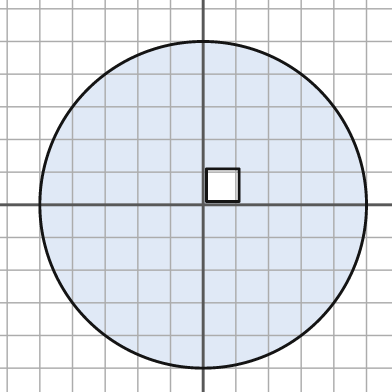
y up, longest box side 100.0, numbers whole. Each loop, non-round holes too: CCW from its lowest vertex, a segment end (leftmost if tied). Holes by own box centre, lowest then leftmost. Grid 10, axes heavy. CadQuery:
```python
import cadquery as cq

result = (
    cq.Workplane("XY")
    .moveTo(0.0, 0.0)
    .circle(50.0)
    .moveTo(1.0, 1.0)
    .lineTo(11.0, 1.0)
    .lineTo(11.0, 11.0)
    .lineTo(1.0, 11.0)
    .close()
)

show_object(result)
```